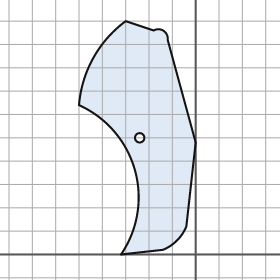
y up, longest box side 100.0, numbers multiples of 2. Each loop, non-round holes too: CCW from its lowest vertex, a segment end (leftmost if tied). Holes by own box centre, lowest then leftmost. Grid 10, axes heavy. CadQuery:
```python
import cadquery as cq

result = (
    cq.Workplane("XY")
    .moveTo(-32.0, 0.0)
    .lineTo(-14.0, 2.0)
    .threePointArc((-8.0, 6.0), (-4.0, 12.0))
    .lineTo(0.0, 48.0)
    .lineTo(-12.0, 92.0)
    .threePointArc((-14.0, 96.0), (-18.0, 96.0))
    .lineTo(-30.0, 100.0)
    .threePointArc((-44.0, 84.0), (-50.0, 64.0))
    .threePointArc((-26.0, 36.0), (-32.0, 0.0))
    .close()
    .moveTo(-24.0, 50.0)
    .circle(2.0)
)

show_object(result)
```